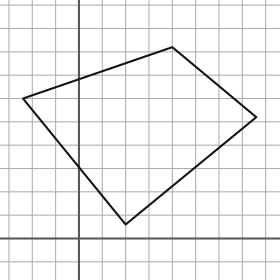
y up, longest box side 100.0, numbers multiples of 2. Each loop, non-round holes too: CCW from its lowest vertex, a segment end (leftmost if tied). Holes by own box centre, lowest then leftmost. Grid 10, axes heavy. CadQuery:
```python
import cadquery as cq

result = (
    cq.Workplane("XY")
    .moveTo(20.0, 6.0)
    .lineTo(76.0, 52.0)
    .lineTo(40.0, 82.0)
    .lineTo(-24.0, 60.0)
    .close()
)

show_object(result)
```